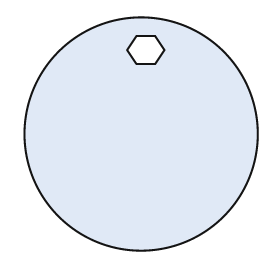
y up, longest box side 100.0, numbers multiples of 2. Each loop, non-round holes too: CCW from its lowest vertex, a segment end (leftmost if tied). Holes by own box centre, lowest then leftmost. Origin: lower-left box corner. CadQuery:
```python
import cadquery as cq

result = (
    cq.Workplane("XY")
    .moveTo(50.0, 50.0)
    .circle(50.0)
    .moveTo(48.0, 80.0)
    .lineTo(56.0, 80.0)
    .lineTo(60.0, 86.0)
    .lineTo(56.0, 92.0)
    .lineTo(48.0, 92.0)
    .lineTo(44.0, 86.0)
    .close()
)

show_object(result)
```